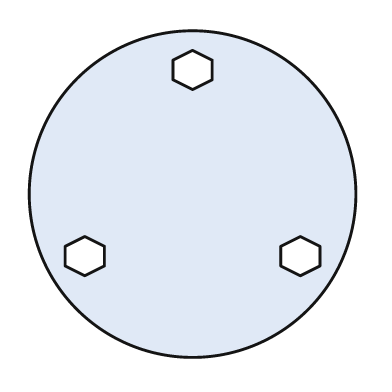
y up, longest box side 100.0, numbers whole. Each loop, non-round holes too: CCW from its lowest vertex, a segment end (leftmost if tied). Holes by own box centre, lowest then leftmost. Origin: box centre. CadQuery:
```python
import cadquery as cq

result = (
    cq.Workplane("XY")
    .moveTo(0.0, 0.0)
    .circle(50.0)
    .moveTo(-33.0, -25.0)
    .lineTo(-27.0, -22.0)
    .lineTo(-27.0, -16.0)
    .lineTo(-33.0, -13.0)
    .lineTo(-39.0, -16.0)
    .lineTo(-39.0, -22.0)
    .close()
    .moveTo(33.0, -25.0)
    .lineTo(39.0, -22.0)
    .lineTo(39.0, -16.0)
    .lineTo(33.0, -13.0)
    .lineTo(27.0, -16.0)
    .lineTo(27.0, -22.0)
    .close()
    .moveTo(0.0, 32.0)
    .lineTo(6.0, 35.0)
    .lineTo(6.0, 41.0)
    .lineTo(0.0, 44.0)
    .lineTo(-6.0, 41.0)
    .lineTo(-6.0, 35.0)
    .close()
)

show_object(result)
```